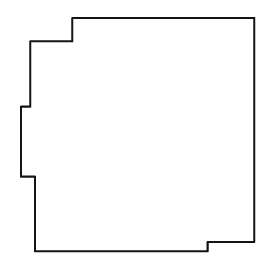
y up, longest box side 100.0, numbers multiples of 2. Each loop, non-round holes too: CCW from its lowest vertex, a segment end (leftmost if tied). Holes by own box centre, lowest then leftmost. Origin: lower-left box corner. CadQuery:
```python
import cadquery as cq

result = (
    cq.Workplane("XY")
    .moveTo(6.0, 0.0)
    .lineTo(80.0, 0.0)
    .lineTo(80.0, 4.0)
    .lineTo(100.0, 4.0)
    .lineTo(100.0, 100.0)
    .lineTo(22.0, 100.0)
    .lineTo(22.0, 90.0)
    .lineTo(4.0, 90.0)
    .lineTo(4.0, 62.0)
    .lineTo(0.0, 62.0)
    .lineTo(0.0, 32.0)
    .lineTo(6.0, 32.0)
    .close()
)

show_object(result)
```